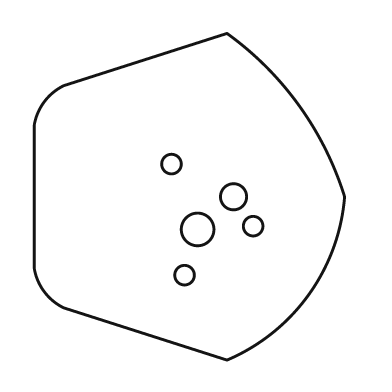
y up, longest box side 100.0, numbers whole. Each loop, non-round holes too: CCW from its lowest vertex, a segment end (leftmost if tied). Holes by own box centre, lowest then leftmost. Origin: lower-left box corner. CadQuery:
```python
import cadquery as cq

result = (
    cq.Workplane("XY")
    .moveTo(59.0, 0.0)
    .threePointArc((84.0, 20.0), (95.0, 50.0))
    .threePointArc((81.0, 78.0), (59.0, 100.0))
    .lineTo(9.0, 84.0)
    .threePointArc((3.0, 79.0), (0.0, 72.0))
    .lineTo(0.0, 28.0)
    .threePointArc((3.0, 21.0), (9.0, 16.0))
    .close()
    .moveTo(46.0, 26.0)
    .circle(3.0)
    .moveTo(50.0, 40.0)
    .circle(5.0)
    .moveTo(67.0, 41.0)
    .circle(3.0)
    .moveTo(61.0, 50.0)
    .circle(4.0)
    .moveTo(42.0, 60.0)
    .circle(3.0)
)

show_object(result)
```